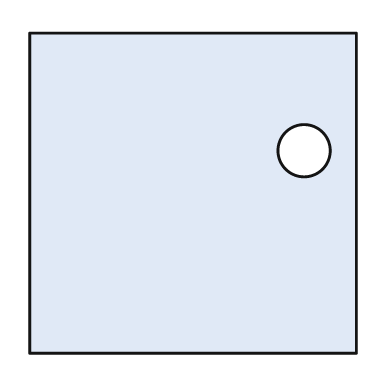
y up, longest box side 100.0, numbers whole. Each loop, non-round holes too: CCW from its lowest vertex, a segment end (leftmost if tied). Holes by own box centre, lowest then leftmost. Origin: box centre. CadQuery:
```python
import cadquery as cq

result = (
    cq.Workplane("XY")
    .moveTo(-50.0, -49.0)
    .lineTo(50.0, -49.0)
    .lineTo(50.0, 49.0)
    .lineTo(-50.0, 49.0)
    .close()
    .moveTo(34.0, 13.0)
    .circle(8.0)
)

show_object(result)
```